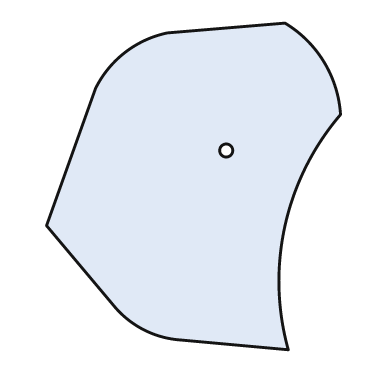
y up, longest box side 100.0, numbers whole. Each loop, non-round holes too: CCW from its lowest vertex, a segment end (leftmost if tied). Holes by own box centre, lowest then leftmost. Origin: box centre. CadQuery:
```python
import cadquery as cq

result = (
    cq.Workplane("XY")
    .moveTo(29.0, -50.0)
    .threePointArc((28.0, -12.0), (45.0, 22.0))
    .threePointArc((40.0, 38.0), (28.0, 50.0))
    .lineTo(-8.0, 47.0)
    .threePointArc((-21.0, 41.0), (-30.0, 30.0))
    .lineTo(-45.0, -12.0)
    .lineTo(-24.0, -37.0)
    .threePointArc((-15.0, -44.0), (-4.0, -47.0))
    .close()
    .moveTo(10.0, 11.0)
    .circle(2.0)
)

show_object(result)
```